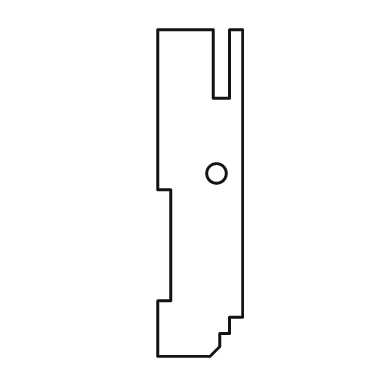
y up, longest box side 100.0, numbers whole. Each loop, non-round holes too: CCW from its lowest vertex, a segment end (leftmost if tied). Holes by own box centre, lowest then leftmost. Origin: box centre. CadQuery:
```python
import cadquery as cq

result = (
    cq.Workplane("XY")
    .moveTo(-13.0, -50.0)
    .lineTo(3.0, -50.0)
    .lineTo(6.0, -47.0)
    .lineTo(6.0, -43.0)
    .lineTo(9.0, -43.0)
    .lineTo(9.0, -38.0)
    .lineTo(13.0, -38.0)
    .lineTo(13.0, 50.0)
    .lineTo(9.0, 50.0)
    .lineTo(9.0, 29.0)
    .lineTo(4.0, 29.0)
    .lineTo(4.0, 50.0)
    .lineTo(-13.0, 50.0)
    .lineTo(-13.0, 1.0)
    .lineTo(-9.0, 1.0)
    .lineTo(-9.0, -33.0)
    .lineTo(-13.0, -33.0)
    .close()
    .moveTo(5.0, 6.0)
    .circle(3.0)
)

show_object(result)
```